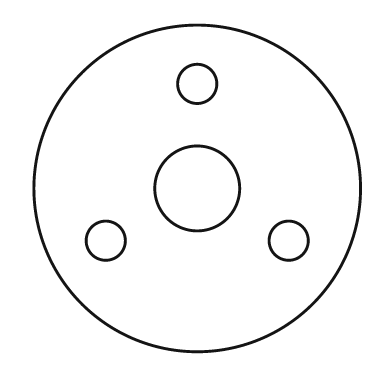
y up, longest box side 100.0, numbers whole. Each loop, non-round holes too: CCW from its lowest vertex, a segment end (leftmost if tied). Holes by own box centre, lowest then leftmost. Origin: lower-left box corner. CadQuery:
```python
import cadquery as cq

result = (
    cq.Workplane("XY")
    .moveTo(50.0, 50.0)
    .circle(50.0)
    .moveTo(22.0, 34.0)
    .circle(6.0)
    .moveTo(78.0, 34.0)
    .circle(6.0)
    .moveTo(50.0, 50.0)
    .circle(13.0)
    .moveTo(50.0, 82.0)
    .circle(6.0)
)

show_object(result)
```